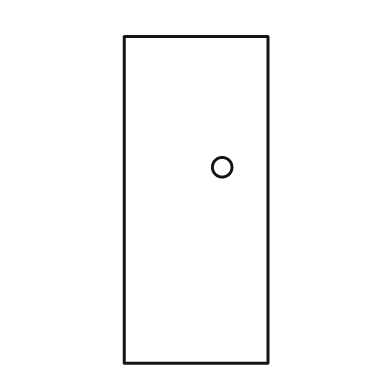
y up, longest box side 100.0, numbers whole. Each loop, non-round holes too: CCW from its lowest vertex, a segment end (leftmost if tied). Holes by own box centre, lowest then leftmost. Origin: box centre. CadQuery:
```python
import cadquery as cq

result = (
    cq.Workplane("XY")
    .moveTo(-22.0, -50.0)
    .lineTo(22.0, -50.0)
    .lineTo(22.0, 50.0)
    .lineTo(-22.0, 50.0)
    .close()
    .moveTo(8.0, 10.0)
    .circle(3.0)
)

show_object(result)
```